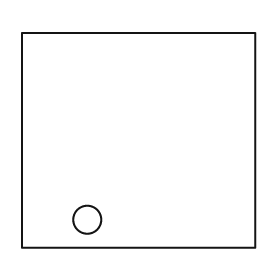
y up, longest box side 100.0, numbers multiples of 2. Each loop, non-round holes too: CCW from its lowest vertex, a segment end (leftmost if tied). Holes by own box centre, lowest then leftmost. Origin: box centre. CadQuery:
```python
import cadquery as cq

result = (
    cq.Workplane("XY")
    .moveTo(-50.0, -46.0)
    .lineTo(50.0, -46.0)
    .lineTo(50.0, 46.0)
    .lineTo(-50.0, 46.0)
    .close()
    .moveTo(-22.0, -34.0)
    .circle(6.0)
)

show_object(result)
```